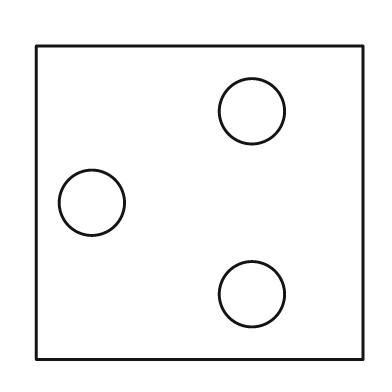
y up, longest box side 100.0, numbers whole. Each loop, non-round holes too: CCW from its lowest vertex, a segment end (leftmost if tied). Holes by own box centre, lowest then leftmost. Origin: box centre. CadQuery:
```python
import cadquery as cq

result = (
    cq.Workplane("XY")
    .moveTo(-50.0, -48.0)
    .lineTo(50.0, -48.0)
    .lineTo(50.0, 48.0)
    .lineTo(-50.0, 48.0)
    .close()
    .moveTo(16.0, -28.0)
    .circle(10.0)
    .moveTo(-33.0, 0.0)
    .circle(10.0)
    .moveTo(16.0, 28.0)
    .circle(10.0)
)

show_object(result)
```